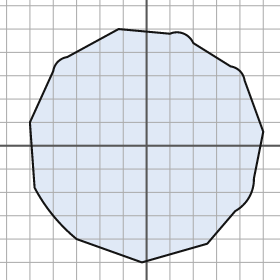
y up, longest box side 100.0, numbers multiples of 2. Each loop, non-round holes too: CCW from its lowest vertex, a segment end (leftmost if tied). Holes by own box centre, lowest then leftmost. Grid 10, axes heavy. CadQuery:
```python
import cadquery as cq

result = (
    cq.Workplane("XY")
    .moveTo(-2.0, -50.0)
    .lineTo(26.0, -42.0)
    .lineTo(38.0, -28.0)
    .threePointArc((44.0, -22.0), (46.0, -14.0))
    .lineTo(50.0, 6.0)
    .lineTo(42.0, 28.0)
    .threePointArc((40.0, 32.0), (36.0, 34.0))
    .lineTo(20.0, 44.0)
    .threePointArc((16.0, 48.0), (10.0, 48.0))
    .lineTo(-12.0, 50.0)
    .lineTo(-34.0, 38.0)
    .threePointArc((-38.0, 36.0), (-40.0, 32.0))
    .lineTo(-50.0, 10.0)
    .lineTo(-48.0, -18.0)
    .threePointArc((-40.0, -30.0), (-30.0, -40.0))
    .close()
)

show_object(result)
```